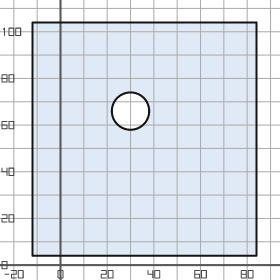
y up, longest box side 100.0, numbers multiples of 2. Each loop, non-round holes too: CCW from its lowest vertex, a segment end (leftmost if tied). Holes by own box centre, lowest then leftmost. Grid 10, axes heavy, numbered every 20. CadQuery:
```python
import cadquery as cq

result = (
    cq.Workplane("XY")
    .moveTo(-12.0, 4.0)
    .lineTo(84.0, 4.0)
    .lineTo(84.0, 104.0)
    .lineTo(-12.0, 104.0)
    .close()
    .moveTo(30.0, 66.0)
    .circle(8.0)
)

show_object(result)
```